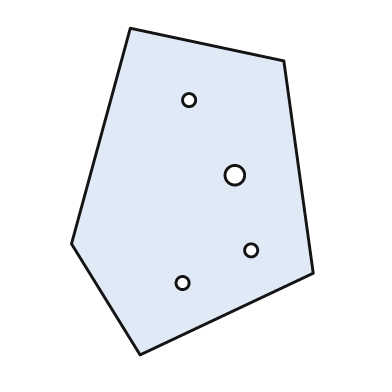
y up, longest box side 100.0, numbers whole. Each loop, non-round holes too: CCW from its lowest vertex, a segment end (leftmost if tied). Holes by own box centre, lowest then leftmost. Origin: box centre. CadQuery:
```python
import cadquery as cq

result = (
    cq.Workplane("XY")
    .moveTo(-16.0, -50.0)
    .lineTo(37.0, -25.0)
    .lineTo(28.0, 40.0)
    .lineTo(-19.0, 50.0)
    .lineTo(-37.0, -16.0)
    .close()
    .moveTo(-3.0, -28.0)
    .circle(2.0)
    .moveTo(18.0, -18.0)
    .circle(2.0)
    .moveTo(13.0, 5.0)
    .circle(3.0)
    .moveTo(-1.0, 28.0)
    .circle(2.0)
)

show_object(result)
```